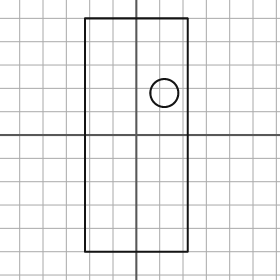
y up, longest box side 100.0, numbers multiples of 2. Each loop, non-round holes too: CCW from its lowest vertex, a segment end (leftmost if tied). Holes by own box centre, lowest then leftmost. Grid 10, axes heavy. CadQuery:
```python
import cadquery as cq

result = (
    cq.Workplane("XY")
    .moveTo(-22.0, -50.0)
    .lineTo(22.0, -50.0)
    .lineTo(22.0, 50.0)
    .lineTo(-22.0, 50.0)
    .close()
    .moveTo(12.0, 18.0)
    .circle(6.0)
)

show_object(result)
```